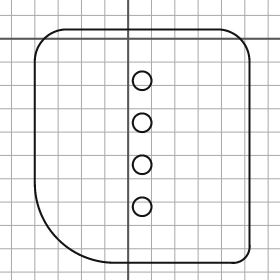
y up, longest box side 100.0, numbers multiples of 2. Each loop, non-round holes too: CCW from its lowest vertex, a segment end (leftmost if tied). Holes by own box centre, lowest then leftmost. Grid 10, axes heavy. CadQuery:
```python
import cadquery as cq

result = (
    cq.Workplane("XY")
    .moveTo(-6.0, -96.0)
    .lineTo(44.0, -96.0)
    .threePointArc((50.0, -94.0), (52.0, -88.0))
    .lineTo(52.0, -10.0)
    .threePointArc((48.0, 0.0), (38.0, 4.0))
    .lineTo(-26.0, 4.0)
    .threePointArc((-36.0, 0.0), (-40.0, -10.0))
    .lineTo(-40.0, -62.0)
    .threePointArc((-30.0, -86.0), (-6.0, -96.0))
    .close()
    .moveTo(6.0, -72.0)
    .circle(4.0)
    .moveTo(6.0, -54.0)
    .circle(4.0)
    .moveTo(6.0, -36.0)
    .circle(4.0)
    .moveTo(6.0, -18.0)
    .circle(4.0)
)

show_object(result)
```